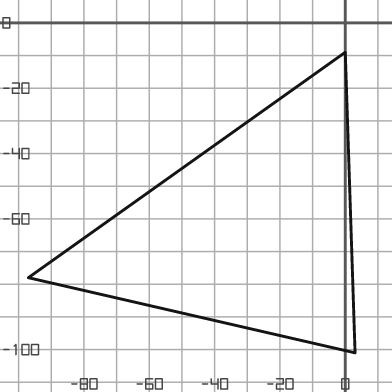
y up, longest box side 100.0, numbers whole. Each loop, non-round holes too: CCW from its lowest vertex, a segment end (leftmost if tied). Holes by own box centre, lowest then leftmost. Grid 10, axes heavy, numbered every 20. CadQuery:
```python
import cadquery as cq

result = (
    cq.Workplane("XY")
    .moveTo(3.0, -101.0)
    .lineTo(0.0, -9.0)
    .lineTo(-97.0, -78.0)
    .close()
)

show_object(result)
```